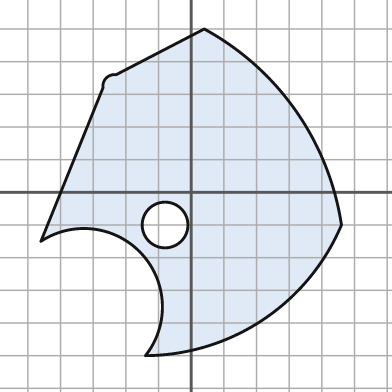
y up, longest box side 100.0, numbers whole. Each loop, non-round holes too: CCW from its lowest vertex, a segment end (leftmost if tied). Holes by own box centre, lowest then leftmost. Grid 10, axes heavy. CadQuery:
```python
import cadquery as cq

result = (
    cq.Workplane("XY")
    .moveTo(-14.0, -50.0)
    .threePointArc((22.0, -39.0), (46.0, -10.0))
    .threePointArc((32.0, 25.0), (4.0, 50.0))
    .lineTo(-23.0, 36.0)
    .threePointArc((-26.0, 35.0), (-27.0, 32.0))
    .lineTo(-46.0, -15.0)
    .threePointArc((-15.0, -19.0), (-14.0, -50.0))
    .close()
    .moveTo(-8.0, -10.0)
    .circle(7.0)
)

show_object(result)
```